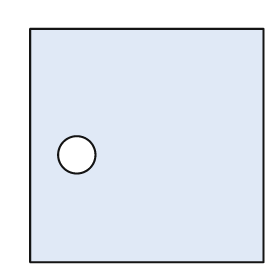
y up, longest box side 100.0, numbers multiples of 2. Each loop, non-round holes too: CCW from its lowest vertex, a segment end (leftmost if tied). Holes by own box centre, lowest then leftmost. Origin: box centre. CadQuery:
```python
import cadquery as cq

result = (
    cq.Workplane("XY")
    .moveTo(-50.0, -50.0)
    .lineTo(50.0, -50.0)
    .lineTo(50.0, 50.0)
    .lineTo(-50.0, 50.0)
    .close()
    .moveTo(-30.0, -4.0)
    .circle(8.0)
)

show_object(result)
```